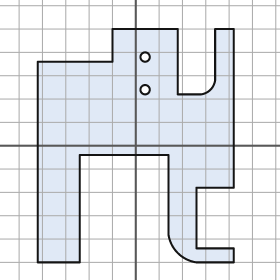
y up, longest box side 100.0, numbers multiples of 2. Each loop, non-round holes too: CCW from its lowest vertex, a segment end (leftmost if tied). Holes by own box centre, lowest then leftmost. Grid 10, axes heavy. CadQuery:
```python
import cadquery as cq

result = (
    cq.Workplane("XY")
    .moveTo(-42.0, -50.0)
    .lineTo(-24.0, -50.0)
    .lineTo(-24.0, -4.0)
    .lineTo(14.0, -4.0)
    .lineTo(14.0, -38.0)
    .threePointArc((18.0, -46.0), (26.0, -50.0))
    .lineTo(42.0, -50.0)
    .lineTo(42.0, -44.0)
    .lineTo(26.0, -44.0)
    .lineTo(26.0, -18.0)
    .lineTo(42.0, -18.0)
    .lineTo(42.0, 50.0)
    .lineTo(34.0, 50.0)
    .lineTo(34.0, 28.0)
    .threePointArc((32.0, 24.0), (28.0, 22.0))
    .lineTo(18.0, 22.0)
    .lineTo(18.0, 50.0)
    .lineTo(-10.0, 50.0)
    .lineTo(-10.0, 36.0)
    .lineTo(-42.0, 36.0)
    .close()
    .moveTo(4.0, 24.0)
    .circle(2.0)
    .moveTo(4.0, 38.0)
    .circle(2.0)
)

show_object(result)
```